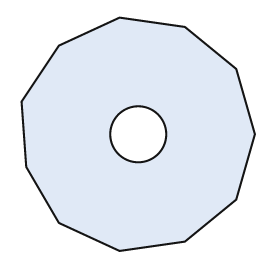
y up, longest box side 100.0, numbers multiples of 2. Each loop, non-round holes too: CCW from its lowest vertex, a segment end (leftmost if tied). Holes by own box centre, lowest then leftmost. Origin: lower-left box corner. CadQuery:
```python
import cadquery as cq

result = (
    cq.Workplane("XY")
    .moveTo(42.0, 0.0)
    .lineTo(70.0, 4.0)
    .lineTo(92.0, 22.0)
    .lineTo(100.0, 50.0)
    .lineTo(92.0, 78.0)
    .lineTo(70.0, 96.0)
    .lineTo(42.0, 100.0)
    .lineTo(16.0, 88.0)
    .lineTo(0.0, 64.0)
    .lineTo(2.0, 36.0)
    .lineTo(16.0, 12.0)
    .close()
    .moveTo(50.0, 50.0)
    .circle(12.0)
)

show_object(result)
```